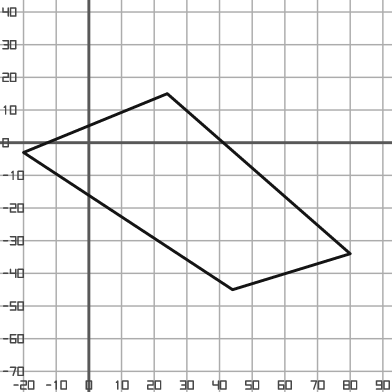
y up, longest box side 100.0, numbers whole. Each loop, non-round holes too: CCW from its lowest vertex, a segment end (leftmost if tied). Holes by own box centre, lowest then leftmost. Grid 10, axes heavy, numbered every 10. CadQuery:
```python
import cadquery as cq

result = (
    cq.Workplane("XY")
    .moveTo(44.0, -45.0)
    .lineTo(80.0, -34.0)
    .lineTo(24.0, 15.0)
    .lineTo(-20.0, -3.0)
    .close()
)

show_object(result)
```